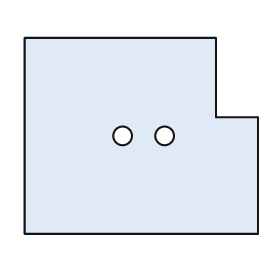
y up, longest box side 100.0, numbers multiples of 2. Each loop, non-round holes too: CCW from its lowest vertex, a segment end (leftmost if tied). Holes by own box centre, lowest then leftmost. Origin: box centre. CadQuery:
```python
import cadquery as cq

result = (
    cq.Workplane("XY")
    .moveTo(-50.0, -42.0)
    .lineTo(50.0, -42.0)
    .lineTo(50.0, 8.0)
    .lineTo(32.0, 8.0)
    .lineTo(32.0, 42.0)
    .lineTo(-50.0, 42.0)
    .close()
    .moveTo(-8.0, 0.0)
    .circle(4.0)
    .moveTo(10.0, 0.0)
    .circle(4.0)
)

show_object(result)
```